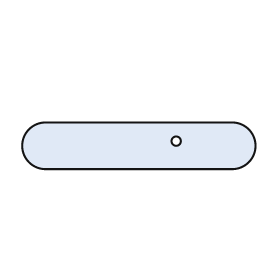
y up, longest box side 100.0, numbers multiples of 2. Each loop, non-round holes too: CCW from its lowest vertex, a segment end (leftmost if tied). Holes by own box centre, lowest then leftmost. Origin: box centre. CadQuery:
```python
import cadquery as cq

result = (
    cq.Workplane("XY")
    .moveTo(-40.0, -10.0)
    .lineTo(40.0, -10.0)
    .threePointArc((50.0, 0.0), (40.0, 10.0))
    .lineTo(-40.0, 10.0)
    .threePointArc((-50.0, 0.0), (-40.0, -10.0))
    .close()
    .moveTo(16.0, 2.0)
    .circle(2.0)
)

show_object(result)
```